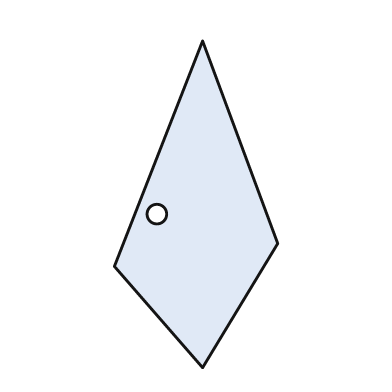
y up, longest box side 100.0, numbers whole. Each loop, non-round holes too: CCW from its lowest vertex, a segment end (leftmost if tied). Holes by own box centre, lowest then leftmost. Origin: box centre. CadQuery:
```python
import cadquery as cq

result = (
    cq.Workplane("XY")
    .moveTo(2.0, -50.0)
    .lineTo(25.0, -12.0)
    .lineTo(2.0, 50.0)
    .lineTo(-25.0, -19.0)
    .close()
    .moveTo(-12.0, -3.0)
    .circle(3.0)
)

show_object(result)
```